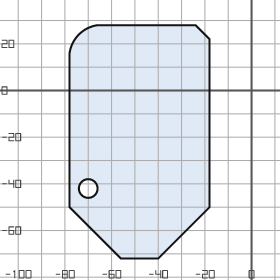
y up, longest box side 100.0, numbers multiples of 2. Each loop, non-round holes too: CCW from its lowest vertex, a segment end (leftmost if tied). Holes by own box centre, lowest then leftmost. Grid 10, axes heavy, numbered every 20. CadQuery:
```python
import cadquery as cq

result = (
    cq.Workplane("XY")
    .moveTo(-56.0, -72.0)
    .lineTo(-40.0, -72.0)
    .lineTo(-18.0, -50.0)
    .lineTo(-18.0, 22.0)
    .lineTo(-24.0, 28.0)
    .lineTo(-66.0, 28.0)
    .threePointArc((-74.0, 24.0), (-78.0, 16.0))
    .lineTo(-78.0, -50.0)
    .close()
    .moveTo(-70.0, -42.0)
    .circle(4.0)
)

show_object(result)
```